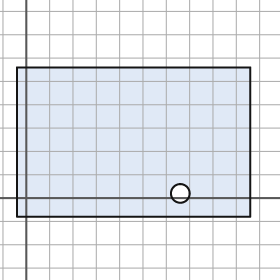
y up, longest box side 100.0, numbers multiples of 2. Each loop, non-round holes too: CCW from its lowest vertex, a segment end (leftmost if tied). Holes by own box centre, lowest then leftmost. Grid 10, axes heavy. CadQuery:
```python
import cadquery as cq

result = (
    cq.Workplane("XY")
    .moveTo(-4.0, -8.0)
    .lineTo(96.0, -8.0)
    .lineTo(96.0, 56.0)
    .lineTo(-4.0, 56.0)
    .close()
    .moveTo(66.0, 2.0)
    .circle(4.0)
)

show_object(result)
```